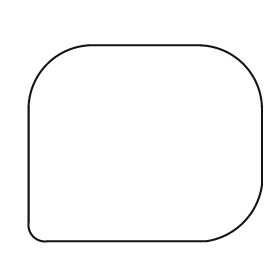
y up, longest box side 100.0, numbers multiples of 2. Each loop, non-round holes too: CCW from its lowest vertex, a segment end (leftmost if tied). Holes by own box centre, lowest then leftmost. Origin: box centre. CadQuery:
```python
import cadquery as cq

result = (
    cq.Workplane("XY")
    .moveTo(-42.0, -42.0)
    .lineTo(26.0, -42.0)
    .threePointArc((42.0, -34.0), (50.0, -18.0))
    .lineTo(50.0, 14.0)
    .threePointArc((42.0, 34.0), (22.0, 42.0))
    .lineTo(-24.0, 42.0)
    .threePointArc((-42.0, 34.0), (-50.0, 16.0))
    .lineTo(-50.0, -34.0)
    .threePointArc((-48.0, -40.0), (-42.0, -42.0))
    .close()
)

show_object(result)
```